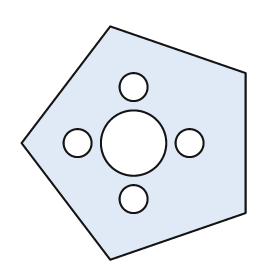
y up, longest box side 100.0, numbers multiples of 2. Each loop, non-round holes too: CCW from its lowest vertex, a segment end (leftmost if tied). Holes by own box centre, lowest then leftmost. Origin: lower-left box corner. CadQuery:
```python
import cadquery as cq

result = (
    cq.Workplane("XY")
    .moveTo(38.0, 0.0)
    .lineTo(96.0, 20.0)
    .lineTo(96.0, 80.0)
    .lineTo(38.0, 100.0)
    .lineTo(0.0, 50.0)
    .close()
    .moveTo(48.0, 26.0)
    .circle(6.0)
    .moveTo(24.0, 50.0)
    .circle(6.0)
    .moveTo(48.0, 50.0)
    .circle(14.0)
    .moveTo(72.0, 50.0)
    .circle(6.0)
    .moveTo(48.0, 74.0)
    .circle(6.0)
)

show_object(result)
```